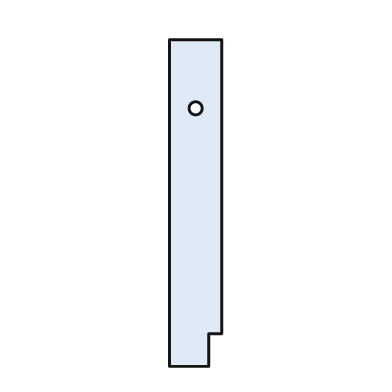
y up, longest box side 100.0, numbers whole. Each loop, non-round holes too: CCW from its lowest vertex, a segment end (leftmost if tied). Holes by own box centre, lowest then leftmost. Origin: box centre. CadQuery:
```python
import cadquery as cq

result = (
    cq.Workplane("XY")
    .moveTo(-8.0, -50.0)
    .lineTo(4.0, -50.0)
    .lineTo(4.0, -40.0)
    .lineTo(8.0, -40.0)
    .lineTo(8.0, 50.0)
    .lineTo(-8.0, 50.0)
    .close()
    .moveTo(0.0, 29.0)
    .circle(2.0)
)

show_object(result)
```